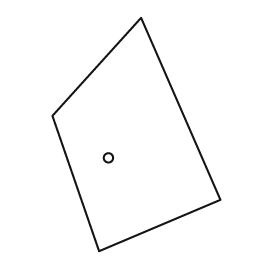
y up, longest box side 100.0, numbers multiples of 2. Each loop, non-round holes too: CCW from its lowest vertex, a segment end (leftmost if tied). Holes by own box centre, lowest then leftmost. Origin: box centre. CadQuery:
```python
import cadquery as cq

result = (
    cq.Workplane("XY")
    .moveTo(-16.0, -50.0)
    .lineTo(36.0, -28.0)
    .lineTo(2.0, 50.0)
    .lineTo(-36.0, 8.0)
    .close()
    .moveTo(-12.0, -10.0)
    .circle(2.0)
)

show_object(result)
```